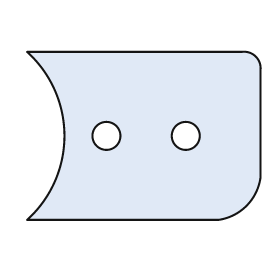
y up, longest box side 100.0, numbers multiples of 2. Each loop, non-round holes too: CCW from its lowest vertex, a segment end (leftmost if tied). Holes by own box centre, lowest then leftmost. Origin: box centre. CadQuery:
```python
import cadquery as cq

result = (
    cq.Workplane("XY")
    .moveTo(-50.0, -36.0)
    .lineTo(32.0, -36.0)
    .threePointArc((44.0, -30.0), (50.0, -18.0))
    .lineTo(50.0, 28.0)
    .threePointArc((48.0, 34.0), (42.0, 36.0))
    .lineTo(-50.0, 36.0)
    .threePointArc((-34.0, 0.0), (-50.0, -36.0))
    .close()
    .moveTo(-16.0, 0.0)
    .circle(6.0)
    .moveTo(18.0, 0.0)
    .circle(6.0)
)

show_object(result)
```